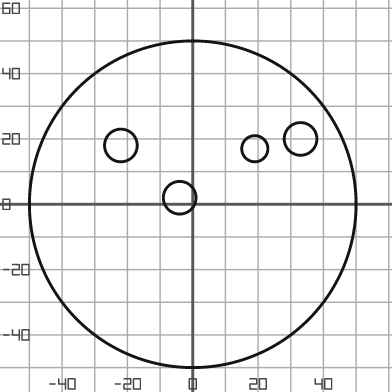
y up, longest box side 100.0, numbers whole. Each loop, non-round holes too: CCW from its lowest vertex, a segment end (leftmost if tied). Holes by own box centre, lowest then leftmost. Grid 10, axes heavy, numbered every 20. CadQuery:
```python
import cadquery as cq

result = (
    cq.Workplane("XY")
    .moveTo(0.0, 0.0)
    .circle(50.0)
    .moveTo(-4.0, 2.0)
    .circle(5.0)
    .moveTo(19.0, 17.0)
    .circle(4.0)
    .moveTo(-22.0, 18.0)
    .circle(5.0)
    .moveTo(33.0, 20.0)
    .circle(5.0)
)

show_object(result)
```